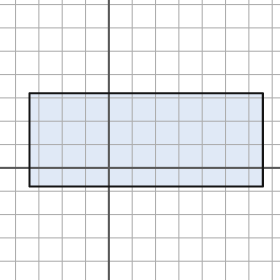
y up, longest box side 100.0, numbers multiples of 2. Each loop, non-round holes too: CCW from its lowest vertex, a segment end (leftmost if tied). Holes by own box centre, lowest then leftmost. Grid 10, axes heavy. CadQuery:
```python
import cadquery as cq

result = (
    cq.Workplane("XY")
    .moveTo(-34.0, -8.0)
    .lineTo(66.0, -8.0)
    .lineTo(66.0, 32.0)
    .lineTo(-34.0, 32.0)
    .close()
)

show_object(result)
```